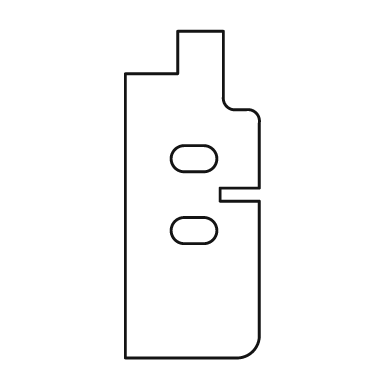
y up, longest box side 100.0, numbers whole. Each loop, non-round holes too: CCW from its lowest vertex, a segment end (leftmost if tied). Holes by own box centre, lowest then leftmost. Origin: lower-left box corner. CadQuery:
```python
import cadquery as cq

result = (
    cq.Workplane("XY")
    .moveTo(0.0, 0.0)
    .lineTo(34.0, 0.0)
    .threePointArc((39.0, 2.0), (41.0, 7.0))
    .lineTo(41.0, 48.0)
    .lineTo(29.0, 48.0)
    .lineTo(29.0, 52.0)
    .lineTo(41.0, 52.0)
    .lineTo(41.0, 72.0)
    .threePointArc((40.0, 75.0), (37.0, 76.0))
    .lineTo(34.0, 76.0)
    .threePointArc((31.0, 77.0), (30.0, 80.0))
    .lineTo(30.0, 100.0)
    .lineTo(16.0, 100.0)
    .lineTo(16.0, 87.0)
    .lineTo(0.0, 87.0)
    .close()
    .moveTo(18.0, 35.0)
    .lineTo(24.0, 35.0)
    .threePointArc((28.0, 39.0), (24.0, 43.0))
    .lineTo(18.0, 43.0)
    .threePointArc((14.0, 39.0), (18.0, 35.0))
    .close()
    .moveTo(18.0, 57.0)
    .lineTo(24.0, 57.0)
    .threePointArc((28.0, 61.0), (24.0, 65.0))
    .lineTo(18.0, 65.0)
    .threePointArc((14.0, 61.0), (18.0, 57.0))
    .close()
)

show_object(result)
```